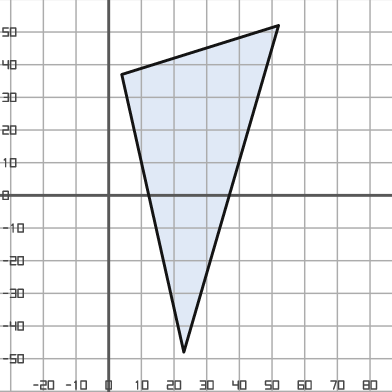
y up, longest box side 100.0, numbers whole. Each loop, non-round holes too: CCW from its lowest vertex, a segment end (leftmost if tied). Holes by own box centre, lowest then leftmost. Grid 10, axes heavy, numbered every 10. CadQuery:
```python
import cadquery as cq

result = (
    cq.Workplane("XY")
    .moveTo(23.0, -48.0)
    .lineTo(52.0, 52.0)
    .lineTo(4.0, 37.0)
    .close()
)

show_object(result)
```